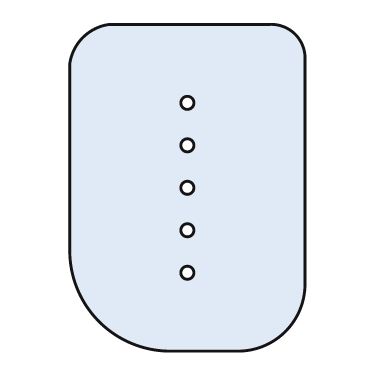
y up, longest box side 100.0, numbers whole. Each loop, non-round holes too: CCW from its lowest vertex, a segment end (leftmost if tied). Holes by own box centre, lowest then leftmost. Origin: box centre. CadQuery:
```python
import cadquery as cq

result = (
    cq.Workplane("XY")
    .moveTo(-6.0, -50.0)
    .lineTo(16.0, -50.0)
    .threePointArc((30.0, -44.0), (36.0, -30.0))
    .lineTo(36.0, 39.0)
    .threePointArc((33.0, 47.0), (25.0, 50.0))
    .lineTo(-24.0, 50.0)
    .threePointArc((-32.0, 46.0), (-36.0, 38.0))
    .lineTo(-36.0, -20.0)
    .threePointArc((-27.0, -41.0), (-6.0, -50.0))
    .close()
    .moveTo(0.0, -26.0)
    .circle(2.0)
    .moveTo(0.0, -13.0)
    .circle(2.0)
    .moveTo(0.0, 0.0)
    .circle(2.0)
    .moveTo(0.0, 13.0)
    .circle(2.0)
    .moveTo(0.0, 26.0)
    .circle(2.0)
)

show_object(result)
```